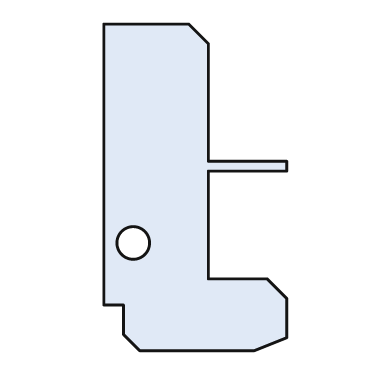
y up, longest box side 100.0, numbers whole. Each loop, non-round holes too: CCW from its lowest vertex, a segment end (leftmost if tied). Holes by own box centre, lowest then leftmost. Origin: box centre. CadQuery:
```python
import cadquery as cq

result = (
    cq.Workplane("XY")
    .moveTo(-17.0, -50.0)
    .lineTo(18.0, -50.0)
    .lineTo(28.0, -46.0)
    .lineTo(28.0, -34.0)
    .lineTo(22.0, -28.0)
    .lineTo(4.0, -28.0)
    .lineTo(4.0, 5.0)
    .lineTo(28.0, 5.0)
    .lineTo(28.0, 8.0)
    .lineTo(4.0, 8.0)
    .lineTo(4.0, 44.0)
    .lineTo(-2.0, 50.0)
    .lineTo(-28.0, 50.0)
    .lineTo(-28.0, -36.0)
    .lineTo(-22.0, -36.0)
    .lineTo(-22.0, -45.0)
    .close()
    .moveTo(-19.0, -17.0)
    .circle(5.0)
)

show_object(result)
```